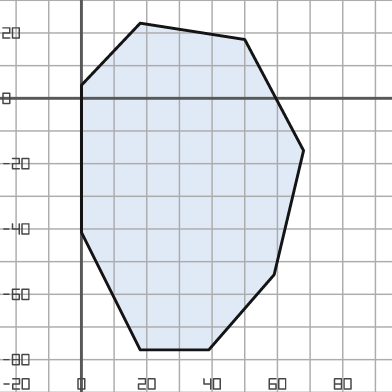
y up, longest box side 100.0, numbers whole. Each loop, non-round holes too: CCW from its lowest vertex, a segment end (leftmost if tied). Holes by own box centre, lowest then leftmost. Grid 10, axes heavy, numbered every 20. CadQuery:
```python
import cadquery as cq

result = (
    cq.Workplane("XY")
    .moveTo(18.0, -77.0)
    .lineTo(39.0, -77.0)
    .lineTo(59.0, -54.0)
    .lineTo(68.0, -16.0)
    .lineTo(50.0, 18.0)
    .lineTo(18.0, 23.0)
    .lineTo(0.0, 4.0)
    .lineTo(0.0, -41.0)
    .close()
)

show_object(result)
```